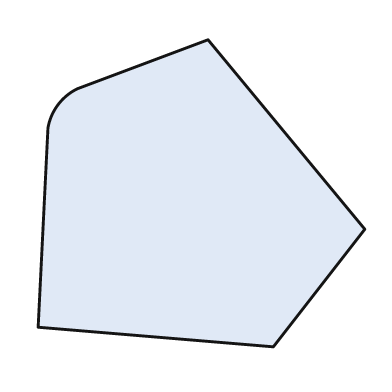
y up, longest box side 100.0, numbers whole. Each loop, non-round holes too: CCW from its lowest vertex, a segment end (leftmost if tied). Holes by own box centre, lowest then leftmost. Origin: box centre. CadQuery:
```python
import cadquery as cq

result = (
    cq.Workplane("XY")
    .moveTo(22.0, -47.0)
    .lineTo(50.0, -11.0)
    .lineTo(2.0, 47.0)
    .lineTo(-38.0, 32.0)
    .threePointArc((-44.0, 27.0), (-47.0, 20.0))
    .lineTo(-50.0, -41.0)
    .close()
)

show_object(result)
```